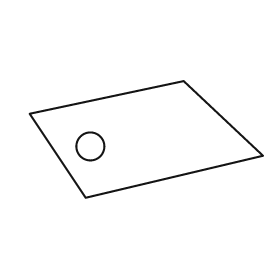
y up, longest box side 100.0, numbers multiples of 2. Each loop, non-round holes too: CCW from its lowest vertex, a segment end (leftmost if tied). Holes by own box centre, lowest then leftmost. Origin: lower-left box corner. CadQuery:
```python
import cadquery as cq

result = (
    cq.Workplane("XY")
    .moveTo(24.0, 0.0)
    .lineTo(100.0, 18.0)
    .lineTo(66.0, 50.0)
    .lineTo(0.0, 36.0)
    .close()
    .moveTo(26.0, 22.0)
    .circle(6.0)
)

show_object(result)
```